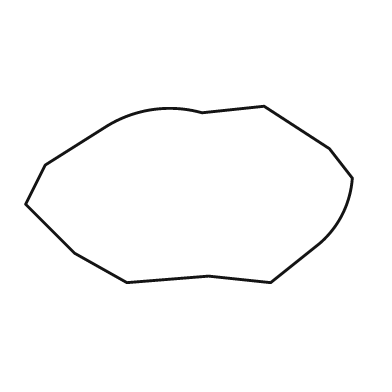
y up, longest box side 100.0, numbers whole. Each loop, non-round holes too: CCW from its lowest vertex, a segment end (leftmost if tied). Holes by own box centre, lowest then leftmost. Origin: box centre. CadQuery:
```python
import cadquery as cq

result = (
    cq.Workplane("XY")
    .moveTo(-19.0, -27.0)
    .lineTo(6.0, -25.0)
    .lineTo(25.0, -27.0)
    .lineTo(40.0, -15.0)
    .threePointArc((47.0, -6.0), (50.0, 5.0))
    .lineTo(43.0, 14.0)
    .lineTo(23.0, 27.0)
    .lineTo(4.0, 25.0)
    .threePointArc((-11.0, 26.0), (-25.0, 21.0))
    .lineTo(-44.0, 9.0)
    .lineTo(-50.0, -3.0)
    .lineTo(-35.0, -18.0)
    .close()
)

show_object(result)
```